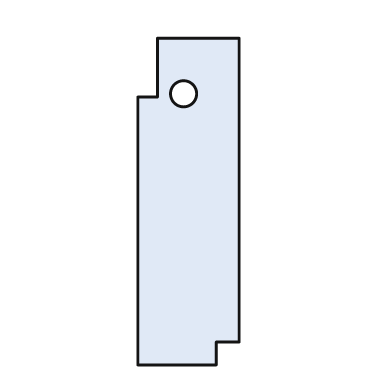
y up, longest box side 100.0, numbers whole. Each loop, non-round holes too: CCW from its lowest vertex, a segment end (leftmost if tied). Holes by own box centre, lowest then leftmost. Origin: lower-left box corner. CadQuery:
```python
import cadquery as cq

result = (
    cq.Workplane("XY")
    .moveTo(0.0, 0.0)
    .lineTo(24.0, 0.0)
    .lineTo(24.0, 7.0)
    .lineTo(31.0, 7.0)
    .lineTo(31.0, 100.0)
    .lineTo(6.0, 100.0)
    .lineTo(6.0, 82.0)
    .lineTo(0.0, 82.0)
    .close()
    .moveTo(14.0, 83.0)
    .circle(4.0)
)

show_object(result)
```